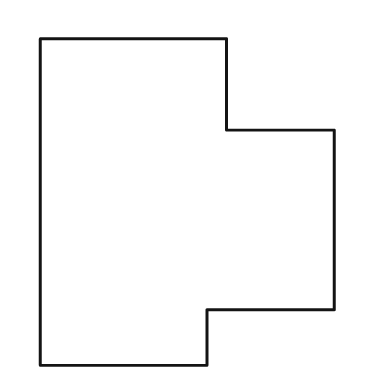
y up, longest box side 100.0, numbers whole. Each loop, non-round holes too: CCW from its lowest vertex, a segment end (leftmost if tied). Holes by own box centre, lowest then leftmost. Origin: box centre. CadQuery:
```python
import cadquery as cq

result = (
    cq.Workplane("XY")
    .moveTo(-45.0, -50.0)
    .lineTo(6.0, -50.0)
    .lineTo(6.0, -33.0)
    .lineTo(45.0, -33.0)
    .lineTo(45.0, 22.0)
    .lineTo(12.0, 22.0)
    .lineTo(12.0, 50.0)
    .lineTo(-45.0, 50.0)
    .close()
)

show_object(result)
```